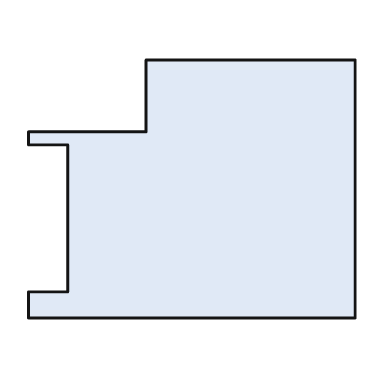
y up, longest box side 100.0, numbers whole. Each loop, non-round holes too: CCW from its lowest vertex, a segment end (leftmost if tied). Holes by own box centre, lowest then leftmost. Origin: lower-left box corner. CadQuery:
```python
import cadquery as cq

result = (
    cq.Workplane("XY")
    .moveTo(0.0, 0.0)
    .lineTo(100.0, 0.0)
    .lineTo(100.0, 79.0)
    .lineTo(36.0, 79.0)
    .lineTo(36.0, 57.0)
    .lineTo(0.0, 57.0)
    .lineTo(0.0, 53.0)
    .lineTo(12.0, 53.0)
    .lineTo(12.0, 8.0)
    .lineTo(0.0, 8.0)
    .close()
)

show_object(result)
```